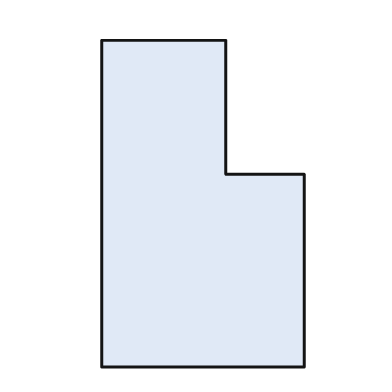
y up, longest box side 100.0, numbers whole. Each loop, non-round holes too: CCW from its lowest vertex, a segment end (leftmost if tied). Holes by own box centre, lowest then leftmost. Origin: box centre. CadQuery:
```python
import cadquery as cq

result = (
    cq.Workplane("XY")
    .moveTo(-31.0, -50.0)
    .lineTo(31.0, -50.0)
    .lineTo(31.0, 9.0)
    .lineTo(7.0, 9.0)
    .lineTo(7.0, 50.0)
    .lineTo(-31.0, 50.0)
    .close()
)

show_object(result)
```